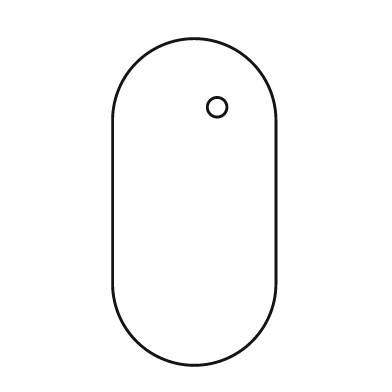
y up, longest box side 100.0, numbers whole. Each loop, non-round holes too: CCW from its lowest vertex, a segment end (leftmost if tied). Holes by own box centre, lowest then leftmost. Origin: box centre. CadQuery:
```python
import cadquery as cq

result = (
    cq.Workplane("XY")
    .moveTo(-25.0, -25.0)
    .threePointArc((0.0, -50.0), (25.0, -25.0))
    .lineTo(25.0, 25.0)
    .threePointArc((0.0, 50.0), (-25.0, 25.0))
    .close()
    .moveTo(7.0, 29.0)
    .circle(3.0)
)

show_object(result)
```